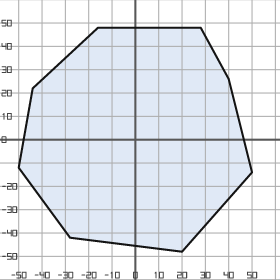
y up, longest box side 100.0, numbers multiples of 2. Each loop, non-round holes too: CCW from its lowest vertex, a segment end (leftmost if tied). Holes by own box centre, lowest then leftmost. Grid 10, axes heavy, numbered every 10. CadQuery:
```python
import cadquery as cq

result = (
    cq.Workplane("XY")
    .moveTo(20.0, -48.0)
    .lineTo(50.0, -14.0)
    .lineTo(40.0, 26.0)
    .lineTo(28.0, 48.0)
    .lineTo(-16.0, 48.0)
    .lineTo(-44.0, 22.0)
    .lineTo(-50.0, -12.0)
    .lineTo(-28.0, -42.0)
    .close()
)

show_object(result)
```